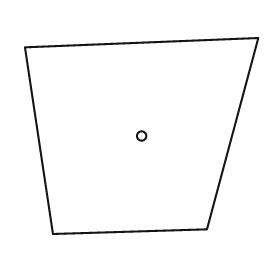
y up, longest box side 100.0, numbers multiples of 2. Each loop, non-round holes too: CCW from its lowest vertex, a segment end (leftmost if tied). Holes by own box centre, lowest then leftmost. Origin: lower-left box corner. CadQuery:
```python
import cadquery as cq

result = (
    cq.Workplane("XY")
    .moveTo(12.0, 0.0)
    .lineTo(78.0, 2.0)
    .lineTo(100.0, 84.0)
    .lineTo(0.0, 80.0)
    .close()
    .moveTo(50.0, 42.0)
    .circle(2.0)
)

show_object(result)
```